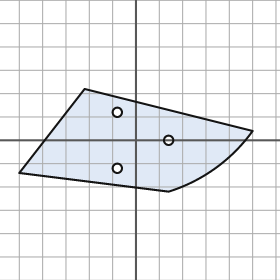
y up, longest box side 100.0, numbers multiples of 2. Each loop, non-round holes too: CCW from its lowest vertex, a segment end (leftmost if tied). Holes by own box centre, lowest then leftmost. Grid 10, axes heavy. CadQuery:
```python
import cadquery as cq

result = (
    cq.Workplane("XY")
    .moveTo(14.0, -22.0)
    .threePointArc((34.0, -12.0), (50.0, 4.0))
    .lineTo(-22.0, 22.0)
    .lineTo(-50.0, -14.0)
    .close()
    .moveTo(-8.0, -12.0)
    .circle(2.0)
    .moveTo(14.0, 0.0)
    .circle(2.0)
    .moveTo(-8.0, 12.0)
    .circle(2.0)
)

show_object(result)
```